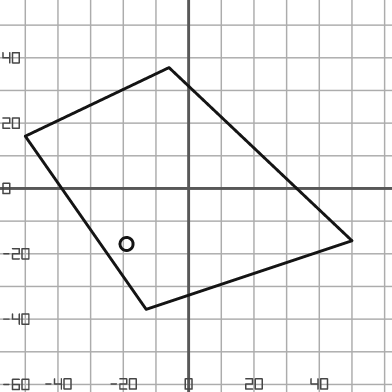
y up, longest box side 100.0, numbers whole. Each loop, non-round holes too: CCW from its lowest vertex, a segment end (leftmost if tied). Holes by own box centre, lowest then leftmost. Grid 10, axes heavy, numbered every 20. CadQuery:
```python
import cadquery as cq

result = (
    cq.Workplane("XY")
    .moveTo(-13.0, -37.0)
    .lineTo(50.0, -16.0)
    .lineTo(-6.0, 37.0)
    .lineTo(-50.0, 16.0)
    .close()
    .moveTo(-19.0, -17.0)
    .circle(2.0)
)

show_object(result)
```